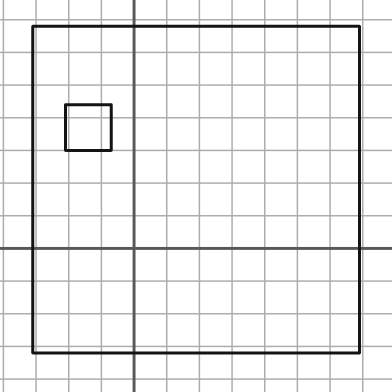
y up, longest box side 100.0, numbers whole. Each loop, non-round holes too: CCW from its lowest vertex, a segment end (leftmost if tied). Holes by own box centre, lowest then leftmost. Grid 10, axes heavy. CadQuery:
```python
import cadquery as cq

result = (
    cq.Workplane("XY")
    .moveTo(-31.0, -32.0)
    .lineTo(69.0, -32.0)
    .lineTo(69.0, 68.0)
    .lineTo(-31.0, 68.0)
    .close()
    .moveTo(-21.0, 30.0)
    .lineTo(-7.0, 30.0)
    .lineTo(-7.0, 44.0)
    .lineTo(-21.0, 44.0)
    .close()
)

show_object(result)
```